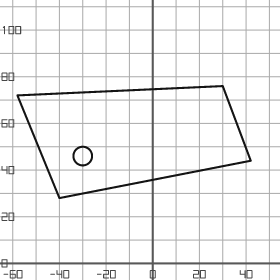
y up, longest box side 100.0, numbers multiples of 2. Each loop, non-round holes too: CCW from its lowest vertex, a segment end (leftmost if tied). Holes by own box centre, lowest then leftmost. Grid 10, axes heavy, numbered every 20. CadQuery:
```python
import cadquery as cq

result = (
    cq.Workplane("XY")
    .moveTo(-40.0, 28.0)
    .lineTo(42.0, 44.0)
    .lineTo(30.0, 76.0)
    .lineTo(-58.0, 72.0)
    .close()
    .moveTo(-30.0, 46.0)
    .circle(4.0)
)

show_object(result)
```